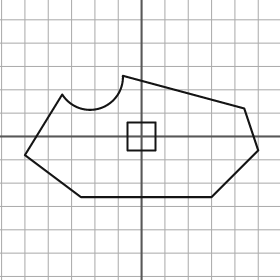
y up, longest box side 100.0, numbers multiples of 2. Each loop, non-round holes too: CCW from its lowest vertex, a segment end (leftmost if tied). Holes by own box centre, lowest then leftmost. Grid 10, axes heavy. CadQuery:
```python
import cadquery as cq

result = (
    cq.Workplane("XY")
    .moveTo(-26.0, -26.0)
    .lineTo(30.0, -26.0)
    .lineTo(50.0, -6.0)
    .lineTo(44.0, 12.0)
    .lineTo(-8.0, 26.0)
    .threePointArc((-18.0, 12.0), (-34.0, 18.0))
    .lineTo(-50.0, -8.0)
    .close()
    .moveTo(-6.0, -6.0)
    .lineTo(6.0, -6.0)
    .lineTo(6.0, 6.0)
    .lineTo(-6.0, 6.0)
    .close()
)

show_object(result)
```